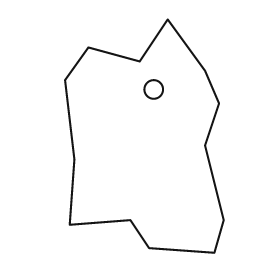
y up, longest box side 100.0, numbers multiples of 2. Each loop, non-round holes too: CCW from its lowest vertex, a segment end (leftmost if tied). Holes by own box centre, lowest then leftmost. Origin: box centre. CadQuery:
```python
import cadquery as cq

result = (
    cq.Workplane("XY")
    .moveTo(30.0, -50.0)
    .lineTo(34.0, -36.0)
    .lineTo(26.0, -4.0)
    .lineTo(32.0, 14.0)
    .lineTo(26.0, 28.0)
    .lineTo(10.0, 50.0)
    .lineTo(-2.0, 32.0)
    .lineTo(-24.0, 38.0)
    .lineTo(-34.0, 24.0)
    .lineTo(-30.0, -10.0)
    .lineTo(-32.0, -38.0)
    .lineTo(-6.0, -36.0)
    .lineTo(2.0, -48.0)
    .close()
    .moveTo(4.0, 20.0)
    .circle(4.0)
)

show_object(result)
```